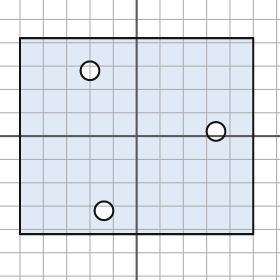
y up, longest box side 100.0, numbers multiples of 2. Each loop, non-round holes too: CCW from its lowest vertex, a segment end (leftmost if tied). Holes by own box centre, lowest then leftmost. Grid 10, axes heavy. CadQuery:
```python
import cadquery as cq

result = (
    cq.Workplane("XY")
    .moveTo(-50.0, -42.0)
    .lineTo(50.0, -42.0)
    .lineTo(50.0, 42.0)
    .lineTo(-50.0, 42.0)
    .close()
    .moveTo(-14.0, -32.0)
    .circle(4.0)
    .moveTo(34.0, 2.0)
    .circle(4.0)
    .moveTo(-20.0, 28.0)
    .circle(4.0)
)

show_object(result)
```